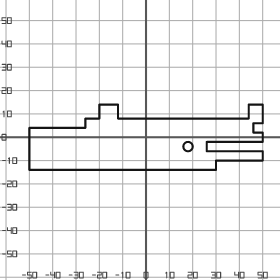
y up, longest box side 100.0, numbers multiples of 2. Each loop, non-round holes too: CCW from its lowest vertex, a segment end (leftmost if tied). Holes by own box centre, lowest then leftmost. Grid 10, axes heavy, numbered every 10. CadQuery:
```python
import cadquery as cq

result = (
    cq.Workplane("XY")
    .moveTo(-50.0, -14.0)
    .lineTo(30.0, -14.0)
    .lineTo(30.0, -10.0)
    .lineTo(50.0, -10.0)
    .lineTo(50.0, -6.0)
    .lineTo(26.0, -6.0)
    .lineTo(26.0, -2.0)
    .lineTo(50.0, -2.0)
    .lineTo(50.0, 2.0)
    .lineTo(46.0, 2.0)
    .lineTo(46.0, 6.0)
    .lineTo(50.0, 6.0)
    .lineTo(50.0, 14.0)
    .lineTo(44.0, 14.0)
    .lineTo(44.0, 8.0)
    .lineTo(-12.0, 8.0)
    .lineTo(-12.0, 14.0)
    .lineTo(-20.0, 14.0)
    .lineTo(-20.0, 8.0)
    .lineTo(-26.0, 8.0)
    .lineTo(-26.0, 4.0)
    .lineTo(-50.0, 4.0)
    .close()
    .moveTo(18.0, -4.0)
    .circle(2.0)
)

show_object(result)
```